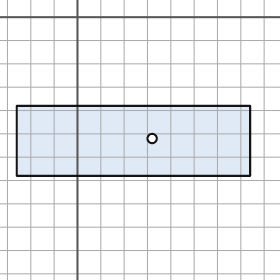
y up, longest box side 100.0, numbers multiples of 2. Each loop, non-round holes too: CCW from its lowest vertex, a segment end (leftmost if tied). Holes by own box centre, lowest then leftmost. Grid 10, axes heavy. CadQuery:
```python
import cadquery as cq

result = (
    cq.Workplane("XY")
    .moveTo(-26.0, -68.0)
    .lineTo(74.0, -68.0)
    .lineTo(74.0, -38.0)
    .lineTo(-26.0, -38.0)
    .close()
    .moveTo(32.0, -52.0)
    .circle(2.0)
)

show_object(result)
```